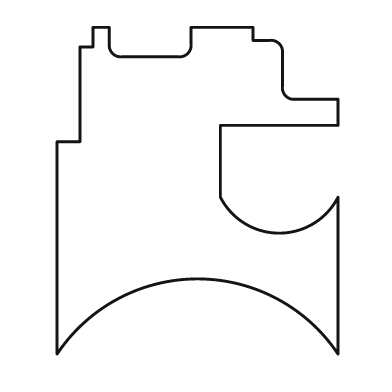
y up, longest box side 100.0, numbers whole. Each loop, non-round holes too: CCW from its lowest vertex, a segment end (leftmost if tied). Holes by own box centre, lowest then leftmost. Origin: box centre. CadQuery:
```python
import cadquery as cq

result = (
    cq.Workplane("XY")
    .moveTo(-43.0, -50.0)
    .threePointArc((0.0, -27.0), (43.0, -50.0))
    .lineTo(43.0, -2.0)
    .threePointArc((25.0, -13.0), (7.0, -2.0))
    .lineTo(7.0, 20.0)
    .lineTo(43.0, 20.0)
    .lineTo(43.0, 28.0)
    .lineTo(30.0, 28.0)
    .threePointArc((27.0, 29.0), (26.0, 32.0))
    .lineTo(26.0, 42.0)
    .threePointArc((25.0, 45.0), (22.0, 46.0))
    .lineTo(17.0, 46.0)
    .lineTo(17.0, 50.0)
    .lineTo(-2.0, 50.0)
    .lineTo(-2.0, 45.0)
    .threePointArc((-3.0, 42.0), (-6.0, 41.0))
    .lineTo(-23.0, 41.0)
    .threePointArc((-26.0, 42.0), (-27.0, 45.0))
    .lineTo(-27.0, 50.0)
    .lineTo(-32.0, 50.0)
    .lineTo(-32.0, 44.0)
    .lineTo(-36.0, 44.0)
    .lineTo(-36.0, 15.0)
    .lineTo(-43.0, 15.0)
    .close()
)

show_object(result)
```